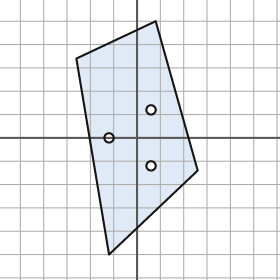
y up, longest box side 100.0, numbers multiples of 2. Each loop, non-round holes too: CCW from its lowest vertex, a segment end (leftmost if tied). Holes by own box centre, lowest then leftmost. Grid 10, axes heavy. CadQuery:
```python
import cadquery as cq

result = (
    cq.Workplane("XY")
    .moveTo(-12.0, -50.0)
    .lineTo(26.0, -14.0)
    .lineTo(8.0, 50.0)
    .lineTo(-26.0, 34.0)
    .close()
    .moveTo(6.0, -12.0)
    .circle(2.0)
    .moveTo(-12.0, 0.0)
    .circle(2.0)
    .moveTo(6.0, 12.0)
    .circle(2.0)
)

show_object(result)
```